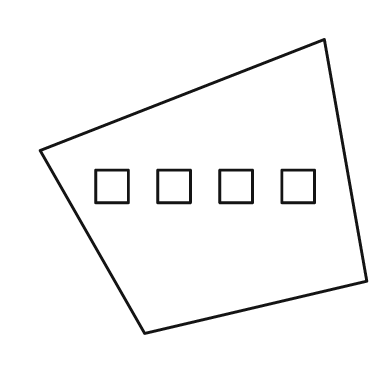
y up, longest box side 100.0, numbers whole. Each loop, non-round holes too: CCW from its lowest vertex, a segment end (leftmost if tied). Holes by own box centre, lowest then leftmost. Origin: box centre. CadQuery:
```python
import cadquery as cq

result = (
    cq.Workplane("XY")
    .moveTo(-18.0, -45.0)
    .lineTo(50.0, -29.0)
    .lineTo(37.0, 45.0)
    .lineTo(-50.0, 11.0)
    .close()
    .moveTo(-33.0, -5.0)
    .lineTo(-23.0, -5.0)
    .lineTo(-23.0, 5.0)
    .lineTo(-33.0, 5.0)
    .close()
    .moveTo(-14.0, -5.0)
    .lineTo(-4.0, -5.0)
    .lineTo(-4.0, 5.0)
    .lineTo(-14.0, 5.0)
    .close()
    .moveTo(5.0, -5.0)
    .lineTo(15.0, -5.0)
    .lineTo(15.0, 5.0)
    .lineTo(5.0, 5.0)
    .close()
    .moveTo(24.0, -5.0)
    .lineTo(34.0, -5.0)
    .lineTo(34.0, 5.0)
    .lineTo(24.0, 5.0)
    .close()
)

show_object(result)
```